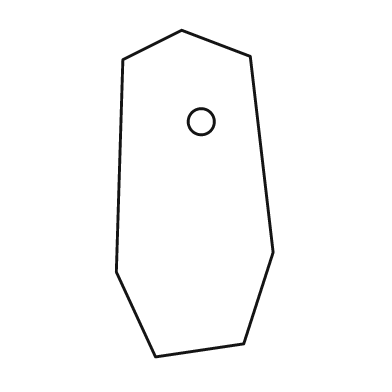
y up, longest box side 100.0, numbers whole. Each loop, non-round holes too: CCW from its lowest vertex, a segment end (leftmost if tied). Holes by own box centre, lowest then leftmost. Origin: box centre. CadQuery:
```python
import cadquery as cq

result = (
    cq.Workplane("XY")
    .moveTo(-12.0, -50.0)
    .lineTo(15.0, -46.0)
    .lineTo(24.0, -18.0)
    .lineTo(17.0, 42.0)
    .lineTo(-4.0, 50.0)
    .lineTo(-22.0, 41.0)
    .lineTo(-24.0, -24.0)
    .close()
    .moveTo(2.0, 22.0)
    .circle(4.0)
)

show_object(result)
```